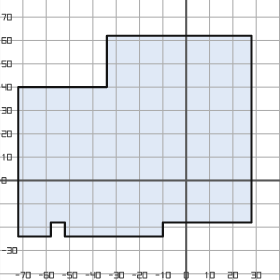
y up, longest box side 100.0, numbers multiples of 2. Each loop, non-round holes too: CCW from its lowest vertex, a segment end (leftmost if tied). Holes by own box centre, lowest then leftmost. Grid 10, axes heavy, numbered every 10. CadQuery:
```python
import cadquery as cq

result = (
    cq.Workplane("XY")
    .moveTo(-72.0, -24.0)
    .lineTo(-58.0, -24.0)
    .lineTo(-58.0, -18.0)
    .lineTo(-52.0, -18.0)
    .lineTo(-52.0, -24.0)
    .lineTo(-10.0, -24.0)
    .lineTo(-10.0, -18.0)
    .lineTo(28.0, -18.0)
    .lineTo(28.0, 62.0)
    .lineTo(-34.0, 62.0)
    .lineTo(-34.0, 40.0)
    .lineTo(-72.0, 40.0)
    .close()
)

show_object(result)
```